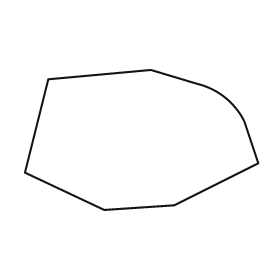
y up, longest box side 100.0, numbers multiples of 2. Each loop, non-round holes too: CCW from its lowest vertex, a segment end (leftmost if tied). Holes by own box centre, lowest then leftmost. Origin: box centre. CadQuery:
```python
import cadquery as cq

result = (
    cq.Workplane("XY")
    .moveTo(-16.0, -30.0)
    .lineTo(14.0, -28.0)
    .lineTo(50.0, -10.0)
    .lineTo(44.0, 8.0)
    .threePointArc((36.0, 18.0), (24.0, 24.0))
    .lineTo(4.0, 30.0)
    .lineTo(-40.0, 26.0)
    .lineTo(-50.0, -14.0)
    .close()
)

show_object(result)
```